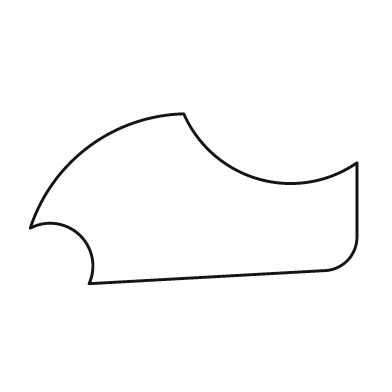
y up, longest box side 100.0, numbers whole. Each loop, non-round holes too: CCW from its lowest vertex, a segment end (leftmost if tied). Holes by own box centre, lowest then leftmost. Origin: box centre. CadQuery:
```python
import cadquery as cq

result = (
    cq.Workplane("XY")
    .moveTo(-32.0, -26.0)
    .lineTo(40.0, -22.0)
    .threePointArc((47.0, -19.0), (50.0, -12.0))
    .lineTo(50.0, 11.0)
    .threePointArc((20.0, 6.0), (-3.0, 26.0))
    .threePointArc((-32.0, 16.0), (-50.0, -9.0))
    .threePointArc((-35.0, -11.0), (-32.0, -26.0))
    .close()
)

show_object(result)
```